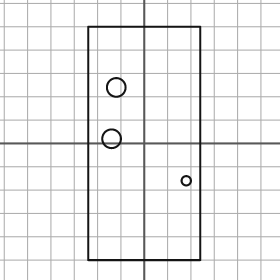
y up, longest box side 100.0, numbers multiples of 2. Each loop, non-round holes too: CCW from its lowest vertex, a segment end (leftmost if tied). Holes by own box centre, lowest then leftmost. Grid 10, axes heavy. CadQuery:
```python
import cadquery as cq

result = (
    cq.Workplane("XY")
    .moveTo(-24.0, -50.0)
    .lineTo(24.0, -50.0)
    .lineTo(24.0, 50.0)
    .lineTo(-24.0, 50.0)
    .close()
    .moveTo(18.0, -16.0)
    .circle(2.0)
    .moveTo(-14.0, 2.0)
    .circle(4.0)
    .moveTo(-12.0, 24.0)
    .circle(4.0)
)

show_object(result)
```